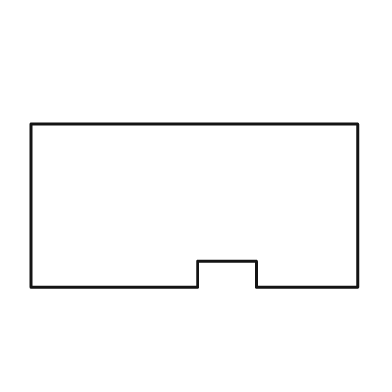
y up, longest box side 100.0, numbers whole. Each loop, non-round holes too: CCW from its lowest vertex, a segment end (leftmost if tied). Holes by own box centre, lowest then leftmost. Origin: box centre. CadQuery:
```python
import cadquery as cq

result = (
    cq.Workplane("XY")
    .moveTo(-50.0, -25.0)
    .lineTo(1.0, -25.0)
    .lineTo(1.0, -17.0)
    .lineTo(19.0, -17.0)
    .lineTo(19.0, -25.0)
    .lineTo(50.0, -25.0)
    .lineTo(50.0, 25.0)
    .lineTo(-50.0, 25.0)
    .close()
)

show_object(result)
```